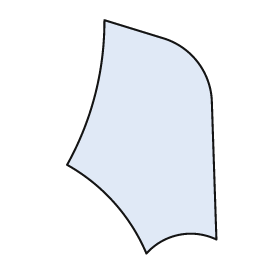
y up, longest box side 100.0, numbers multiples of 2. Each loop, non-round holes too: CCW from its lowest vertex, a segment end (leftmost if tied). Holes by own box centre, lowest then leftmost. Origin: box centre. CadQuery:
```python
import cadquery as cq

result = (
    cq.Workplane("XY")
    .moveTo(2.0, -50.0)
    .threePointArc((16.0, -42.0), (32.0, -44.0))
    .lineTo(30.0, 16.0)
    .threePointArc((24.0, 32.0), (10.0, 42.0))
    .lineTo(-16.0, 50.0)
    .threePointArc((-20.0, 18.0), (-32.0, -12.0))
    .threePointArc((-12.0, -28.0), (2.0, -50.0))
    .close()
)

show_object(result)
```